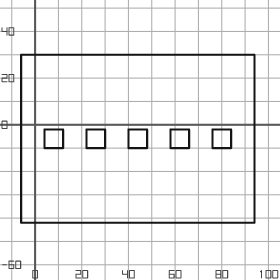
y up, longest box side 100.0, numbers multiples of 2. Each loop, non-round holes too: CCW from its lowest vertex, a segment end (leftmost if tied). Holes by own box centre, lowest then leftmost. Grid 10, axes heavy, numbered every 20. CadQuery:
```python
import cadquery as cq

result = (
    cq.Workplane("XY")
    .moveTo(-6.0, -42.0)
    .lineTo(94.0, -42.0)
    .lineTo(94.0, 30.0)
    .lineTo(-6.0, 30.0)
    .close()
    .moveTo(4.0, -10.0)
    .lineTo(12.0, -10.0)
    .lineTo(12.0, -2.0)
    .lineTo(4.0, -2.0)
    .close()
    .moveTo(22.0, -10.0)
    .lineTo(30.0, -10.0)
    .lineTo(30.0, -2.0)
    .lineTo(22.0, -2.0)
    .close()
    .moveTo(40.0, -10.0)
    .lineTo(48.0, -10.0)
    .lineTo(48.0, -2.0)
    .lineTo(40.0, -2.0)
    .close()
    .moveTo(58.0, -10.0)
    .lineTo(66.0, -10.0)
    .lineTo(66.0, -2.0)
    .lineTo(58.0, -2.0)
    .close()
    .moveTo(76.0, -10.0)
    .lineTo(84.0, -10.0)
    .lineTo(84.0, -2.0)
    .lineTo(76.0, -2.0)
    .close()
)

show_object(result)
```